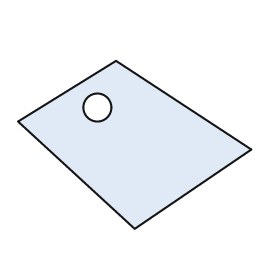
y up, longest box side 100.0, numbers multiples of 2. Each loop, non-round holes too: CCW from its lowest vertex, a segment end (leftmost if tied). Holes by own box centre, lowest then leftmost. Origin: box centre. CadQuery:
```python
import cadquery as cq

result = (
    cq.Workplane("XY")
    .moveTo(0.0, -36.0)
    .lineTo(50.0, -2.0)
    .lineTo(-8.0, 36.0)
    .lineTo(-50.0, 10.0)
    .close()
    .moveTo(-16.0, 16.0)
    .circle(6.0)
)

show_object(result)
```